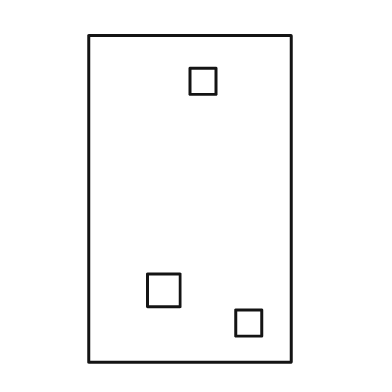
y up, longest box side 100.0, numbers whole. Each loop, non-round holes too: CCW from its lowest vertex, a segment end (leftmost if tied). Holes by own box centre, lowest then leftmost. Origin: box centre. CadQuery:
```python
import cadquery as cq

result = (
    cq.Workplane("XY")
    .moveTo(-31.0, -50.0)
    .lineTo(31.0, -50.0)
    .lineTo(31.0, 50.0)
    .lineTo(-31.0, 50.0)
    .close()
    .moveTo(14.0, -42.0)
    .lineTo(22.0, -42.0)
    .lineTo(22.0, -34.0)
    .lineTo(14.0, -34.0)
    .close()
    .moveTo(-13.0, -33.0)
    .lineTo(-3.0, -33.0)
    .lineTo(-3.0, -23.0)
    .lineTo(-13.0, -23.0)
    .close()
    .moveTo(0.0, 32.0)
    .lineTo(8.0, 32.0)
    .lineTo(8.0, 40.0)
    .lineTo(0.0, 40.0)
    .close()
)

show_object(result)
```